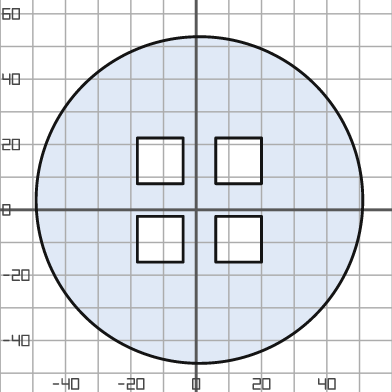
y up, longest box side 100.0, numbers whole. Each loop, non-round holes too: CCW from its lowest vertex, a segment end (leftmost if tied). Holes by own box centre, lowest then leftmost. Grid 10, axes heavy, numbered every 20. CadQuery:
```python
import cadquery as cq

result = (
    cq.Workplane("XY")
    .moveTo(1.0, 3.0)
    .circle(50.0)
    .moveTo(-18.0, -16.0)
    .lineTo(-4.0, -16.0)
    .lineTo(-4.0, -2.0)
    .lineTo(-18.0, -2.0)
    .close()
    .moveTo(6.0, -16.0)
    .lineTo(20.0, -16.0)
    .lineTo(20.0, -2.0)
    .lineTo(6.0, -2.0)
    .close()
    .moveTo(-18.0, 8.0)
    .lineTo(-4.0, 8.0)
    .lineTo(-4.0, 22.0)
    .lineTo(-18.0, 22.0)
    .close()
    .moveTo(6.0, 8.0)
    .lineTo(20.0, 8.0)
    .lineTo(20.0, 22.0)
    .lineTo(6.0, 22.0)
    .close()
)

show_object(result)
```